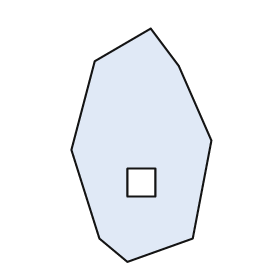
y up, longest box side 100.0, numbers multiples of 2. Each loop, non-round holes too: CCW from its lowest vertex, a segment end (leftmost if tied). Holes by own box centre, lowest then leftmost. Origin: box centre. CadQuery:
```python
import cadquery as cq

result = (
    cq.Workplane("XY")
    .moveTo(-6.0, -50.0)
    .lineTo(22.0, -40.0)
    .lineTo(30.0, 2.0)
    .lineTo(16.0, 34.0)
    .lineTo(4.0, 50.0)
    .lineTo(-20.0, 36.0)
    .lineTo(-30.0, -2.0)
    .lineTo(-18.0, -40.0)
    .close()
    .moveTo(-6.0, -22.0)
    .lineTo(6.0, -22.0)
    .lineTo(6.0, -10.0)
    .lineTo(-6.0, -10.0)
    .close()
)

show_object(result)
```